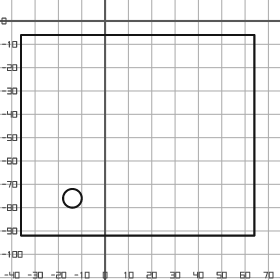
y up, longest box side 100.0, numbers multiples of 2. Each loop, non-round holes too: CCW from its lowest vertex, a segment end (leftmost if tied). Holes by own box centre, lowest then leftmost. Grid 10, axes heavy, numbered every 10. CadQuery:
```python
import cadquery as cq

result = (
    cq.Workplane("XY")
    .moveTo(-36.0, -92.0)
    .lineTo(64.0, -92.0)
    .lineTo(64.0, -6.0)
    .lineTo(-36.0, -6.0)
    .close()
    .moveTo(-14.0, -76.0)
    .circle(4.0)
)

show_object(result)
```